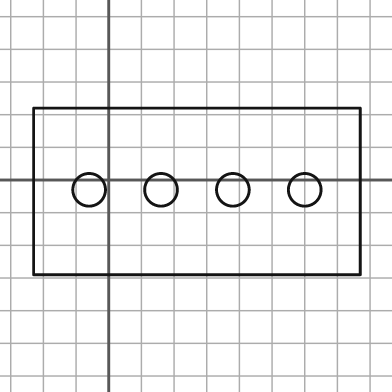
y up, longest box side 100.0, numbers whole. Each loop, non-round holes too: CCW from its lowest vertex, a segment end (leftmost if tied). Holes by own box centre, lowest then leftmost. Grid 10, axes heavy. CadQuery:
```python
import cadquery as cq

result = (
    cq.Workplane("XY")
    .moveTo(-23.0, -29.0)
    .lineTo(77.0, -29.0)
    .lineTo(77.0, 22.0)
    .lineTo(-23.0, 22.0)
    .close()
    .moveTo(-6.0, -3.0)
    .circle(5.0)
    .moveTo(16.0, -3.0)
    .circle(5.0)
    .moveTo(38.0, -3.0)
    .circle(5.0)
    .moveTo(60.0, -3.0)
    .circle(5.0)
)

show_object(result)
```